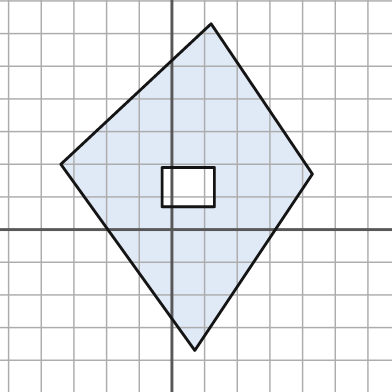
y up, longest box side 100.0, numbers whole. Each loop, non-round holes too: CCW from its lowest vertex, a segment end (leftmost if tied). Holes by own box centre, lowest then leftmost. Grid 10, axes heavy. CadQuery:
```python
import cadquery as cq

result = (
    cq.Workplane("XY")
    .moveTo(7.0, -37.0)
    .lineTo(43.0, 17.0)
    .lineTo(12.0, 63.0)
    .lineTo(-34.0, 20.0)
    .close()
    .moveTo(-3.0, 7.0)
    .lineTo(13.0, 7.0)
    .lineTo(13.0, 19.0)
    .lineTo(-3.0, 19.0)
    .close()
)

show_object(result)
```